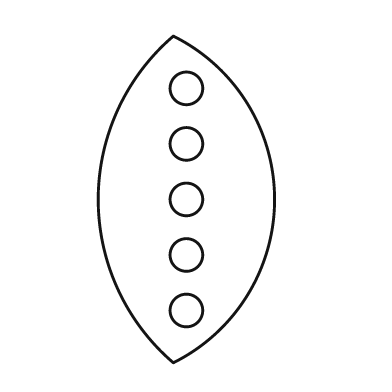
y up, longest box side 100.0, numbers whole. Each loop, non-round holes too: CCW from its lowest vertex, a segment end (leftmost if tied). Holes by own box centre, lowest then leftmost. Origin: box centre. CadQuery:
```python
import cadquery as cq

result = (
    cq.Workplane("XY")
    .moveTo(-4.0, -50.0)
    .threePointArc((27.0, 0.0), (-4.0, 50.0))
    .threePointArc((-27.0, 0.0), (-4.0, -50.0))
    .close()
    .moveTo(0.0, -34.0)
    .circle(5.0)
    .moveTo(0.0, -17.0)
    .circle(5.0)
    .moveTo(0.0, 0.0)
    .circle(5.0)
    .moveTo(0.0, 17.0)
    .circle(5.0)
    .moveTo(0.0, 34.0)
    .circle(5.0)
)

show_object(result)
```